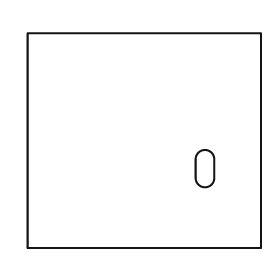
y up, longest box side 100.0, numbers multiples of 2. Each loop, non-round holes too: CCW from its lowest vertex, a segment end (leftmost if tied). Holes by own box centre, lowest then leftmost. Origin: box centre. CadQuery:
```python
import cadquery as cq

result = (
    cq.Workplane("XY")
    .moveTo(-50.0, -46.0)
    .lineTo(50.0, -46.0)
    .lineTo(50.0, 46.0)
    .lineTo(-50.0, 46.0)
    .close()
    .moveTo(22.0, -16.0)
    .threePointArc((26.0, -20.0), (30.0, -16.0))
    .lineTo(30.0, -8.0)
    .threePointArc((26.0, -4.0), (22.0, -8.0))
    .close()
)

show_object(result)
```